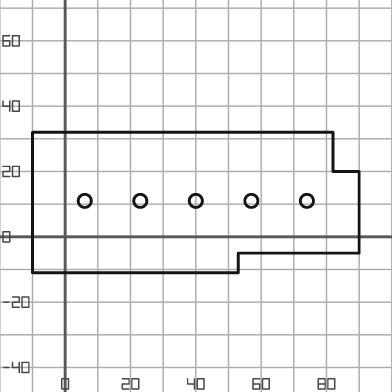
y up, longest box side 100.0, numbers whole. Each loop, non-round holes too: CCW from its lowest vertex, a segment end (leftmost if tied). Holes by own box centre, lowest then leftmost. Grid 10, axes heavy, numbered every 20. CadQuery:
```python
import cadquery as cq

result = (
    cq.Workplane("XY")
    .moveTo(-10.0, -11.0)
    .lineTo(53.0, -11.0)
    .lineTo(53.0, -5.0)
    .lineTo(90.0, -5.0)
    .lineTo(90.0, 20.0)
    .lineTo(82.0, 20.0)
    .lineTo(82.0, 32.0)
    .lineTo(-10.0, 32.0)
    .close()
    .moveTo(6.0, 11.0)
    .circle(2.0)
    .moveTo(23.0, 11.0)
    .circle(2.0)
    .moveTo(40.0, 11.0)
    .circle(2.0)
    .moveTo(57.0, 11.0)
    .circle(2.0)
    .moveTo(74.0, 11.0)
    .circle(2.0)
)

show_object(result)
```